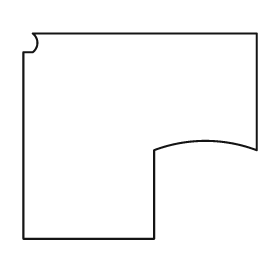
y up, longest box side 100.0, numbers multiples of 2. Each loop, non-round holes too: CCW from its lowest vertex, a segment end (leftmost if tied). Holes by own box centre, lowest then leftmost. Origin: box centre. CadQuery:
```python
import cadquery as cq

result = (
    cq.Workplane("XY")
    .moveTo(-50.0, -44.0)
    .lineTo(6.0, -44.0)
    .lineTo(6.0, -6.0)
    .threePointArc((28.0, -2.0), (50.0, -6.0))
    .lineTo(50.0, 44.0)
    .lineTo(-46.0, 44.0)
    .threePointArc((-44.0, 40.0), (-46.0, 36.0))
    .lineTo(-50.0, 36.0)
    .close()
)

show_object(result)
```